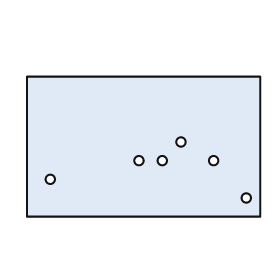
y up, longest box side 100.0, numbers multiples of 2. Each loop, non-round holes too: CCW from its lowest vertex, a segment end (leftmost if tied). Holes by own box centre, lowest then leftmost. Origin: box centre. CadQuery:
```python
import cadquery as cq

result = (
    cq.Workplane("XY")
    .moveTo(-50.0, -30.0)
    .lineTo(50.0, -30.0)
    .lineTo(50.0, 30.0)
    .lineTo(-50.0, 30.0)
    .close()
    .moveTo(44.0, -22.0)
    .circle(2.0)
    .moveTo(-40.0, -14.0)
    .circle(2.0)
    .moveTo(-2.0, -6.0)
    .circle(2.0)
    .moveTo(8.0, -6.0)
    .circle(2.0)
    .moveTo(30.0, -6.0)
    .circle(2.0)
    .moveTo(16.0, 2.0)
    .circle(2.0)
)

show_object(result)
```